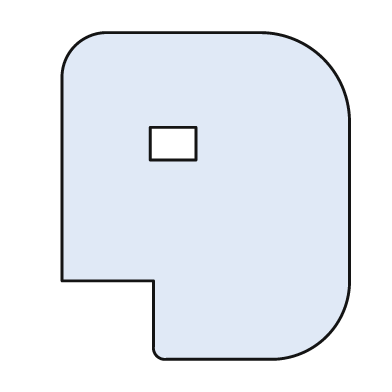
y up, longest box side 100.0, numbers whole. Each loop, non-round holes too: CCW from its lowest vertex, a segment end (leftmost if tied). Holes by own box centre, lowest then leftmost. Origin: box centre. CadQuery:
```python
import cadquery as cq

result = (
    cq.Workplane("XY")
    .moveTo(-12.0, -50.0)
    .lineTo(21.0, -50.0)
    .threePointArc((37.0, -43.0), (44.0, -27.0))
    .lineTo(44.0, 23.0)
    .threePointArc((36.0, 42.0), (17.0, 50.0))
    .lineTo(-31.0, 50.0)
    .threePointArc((-40.0, 46.0), (-44.0, 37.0))
    .lineTo(-44.0, -26.0)
    .lineTo(-16.0, -26.0)
    .lineTo(-16.0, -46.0)
    .threePointArc((-15.0, -49.0), (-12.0, -50.0))
    .close()
    .moveTo(-17.0, 11.0)
    .lineTo(-3.0, 11.0)
    .lineTo(-3.0, 21.0)
    .lineTo(-17.0, 21.0)
    .close()
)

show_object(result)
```